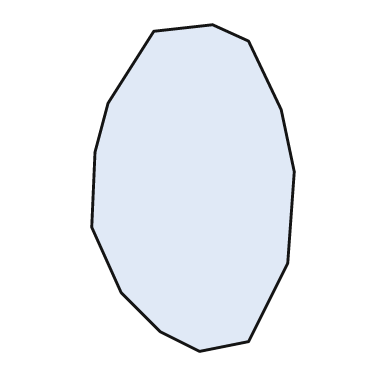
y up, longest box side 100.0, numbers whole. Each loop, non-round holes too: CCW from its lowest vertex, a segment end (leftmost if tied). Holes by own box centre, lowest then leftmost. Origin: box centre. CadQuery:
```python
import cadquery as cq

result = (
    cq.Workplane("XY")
    .moveTo(2.0, -50.0)
    .lineTo(17.0, -47.0)
    .lineTo(29.0, -23.0)
    .lineTo(31.0, 5.0)
    .lineTo(27.0, 24.0)
    .lineTo(17.0, 45.0)
    .lineTo(6.0, 50.0)
    .lineTo(-12.0, 48.0)
    .lineTo(-26.0, 26.0)
    .lineTo(-30.0, 11.0)
    .lineTo(-31.0, -12.0)
    .lineTo(-22.0, -32.0)
    .lineTo(-10.0, -44.0)
    .close()
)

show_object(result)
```